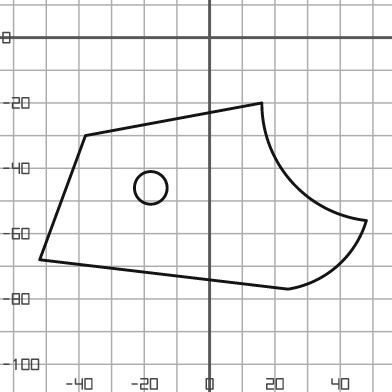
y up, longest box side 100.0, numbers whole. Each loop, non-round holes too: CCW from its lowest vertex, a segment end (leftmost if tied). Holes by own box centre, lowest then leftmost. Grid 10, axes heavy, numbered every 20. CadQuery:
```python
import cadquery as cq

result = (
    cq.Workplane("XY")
    .moveTo(24.0, -77.0)
    .threePointArc((39.0, -70.0), (48.0, -56.0))
    .threePointArc((25.0, -44.0), (16.0, -20.0))
    .lineTo(-38.0, -30.0)
    .lineTo(-52.0, -68.0)
    .close()
    .moveTo(-18.0, -46.0)
    .circle(5.0)
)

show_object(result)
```